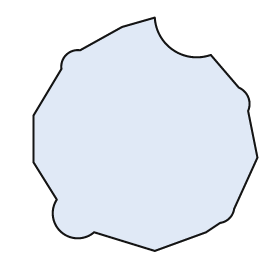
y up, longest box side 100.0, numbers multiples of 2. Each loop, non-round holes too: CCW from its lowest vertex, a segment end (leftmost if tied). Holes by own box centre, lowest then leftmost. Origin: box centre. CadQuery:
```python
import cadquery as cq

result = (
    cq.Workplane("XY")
    .moveTo(4.0, -50.0)
    .lineTo(26.0, -42.0)
    .lineTo(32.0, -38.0)
    .threePointArc((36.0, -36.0), (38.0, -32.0))
    .lineTo(48.0, -10.0)
    .lineTo(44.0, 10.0)
    .threePointArc((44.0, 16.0), (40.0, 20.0))
    .lineTo(28.0, 34.0)
    .threePointArc((12.0, 36.0), (4.0, 50.0))
    .lineTo(-10.0, 46.0)
    .lineTo(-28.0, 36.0)
    .threePointArc((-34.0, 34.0), (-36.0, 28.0))
    .lineTo(-48.0, 8.0)
    .lineTo(-48.0, -12.0)
    .lineTo(-38.0, -28.0)
    .threePointArc((-36.0, -42.0), (-22.0, -42.0))
    .close()
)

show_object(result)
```